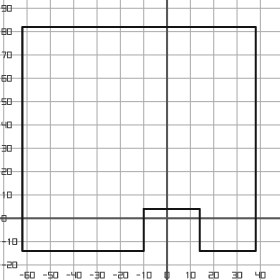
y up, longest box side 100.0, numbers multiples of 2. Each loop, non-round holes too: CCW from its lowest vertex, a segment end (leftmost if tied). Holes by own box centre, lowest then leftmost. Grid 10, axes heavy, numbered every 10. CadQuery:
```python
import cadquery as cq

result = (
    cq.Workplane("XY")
    .moveTo(-62.0, -14.0)
    .lineTo(-10.0, -14.0)
    .lineTo(-10.0, 4.0)
    .lineTo(14.0, 4.0)
    .lineTo(14.0, -14.0)
    .lineTo(38.0, -14.0)
    .lineTo(38.0, 82.0)
    .lineTo(-62.0, 82.0)
    .close()
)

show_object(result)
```